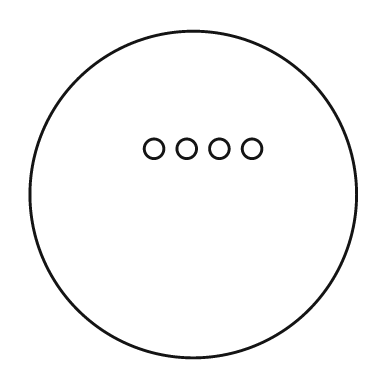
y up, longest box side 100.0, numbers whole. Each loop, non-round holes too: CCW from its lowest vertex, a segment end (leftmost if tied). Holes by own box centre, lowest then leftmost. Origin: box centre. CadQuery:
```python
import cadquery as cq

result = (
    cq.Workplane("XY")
    .moveTo(0.0, 0.0)
    .circle(50.0)
    .moveTo(-12.0, 14.0)
    .circle(3.0)
    .moveTo(-2.0, 14.0)
    .circle(3.0)
    .moveTo(8.0, 14.0)
    .circle(3.0)
    .moveTo(18.0, 14.0)
    .circle(3.0)
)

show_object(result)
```